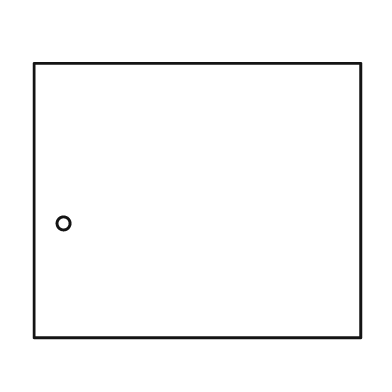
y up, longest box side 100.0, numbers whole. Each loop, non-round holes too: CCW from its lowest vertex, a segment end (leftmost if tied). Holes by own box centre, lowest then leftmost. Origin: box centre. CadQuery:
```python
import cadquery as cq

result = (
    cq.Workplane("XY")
    .moveTo(-50.0, -42.0)
    .lineTo(50.0, -42.0)
    .lineTo(50.0, 42.0)
    .lineTo(-50.0, 42.0)
    .close()
    .moveTo(-41.0, -7.0)
    .circle(2.0)
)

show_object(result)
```